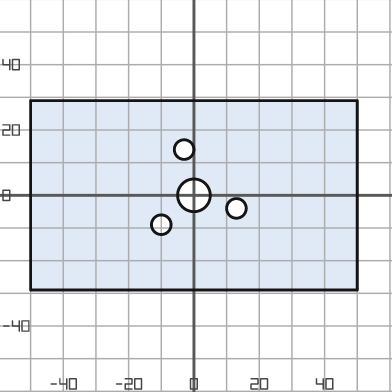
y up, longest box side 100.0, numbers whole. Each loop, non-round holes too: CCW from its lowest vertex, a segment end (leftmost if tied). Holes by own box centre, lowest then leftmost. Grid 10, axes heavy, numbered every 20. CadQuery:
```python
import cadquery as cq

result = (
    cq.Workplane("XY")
    .moveTo(-50.0, -29.0)
    .lineTo(50.0, -29.0)
    .lineTo(50.0, 29.0)
    .lineTo(-50.0, 29.0)
    .close()
    .moveTo(-10.0, -9.0)
    .circle(3.0)
    .moveTo(13.0, -4.0)
    .circle(3.0)
    .moveTo(0.0, 0.0)
    .circle(5.0)
    .moveTo(-3.0, 14.0)
    .circle(3.0)
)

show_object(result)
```